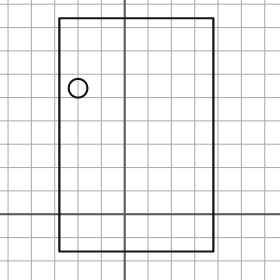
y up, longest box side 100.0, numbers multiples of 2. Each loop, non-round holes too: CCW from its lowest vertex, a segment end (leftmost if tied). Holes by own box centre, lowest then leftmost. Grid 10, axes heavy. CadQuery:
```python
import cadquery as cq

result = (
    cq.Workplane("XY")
    .moveTo(-28.0, -16.0)
    .lineTo(38.0, -16.0)
    .lineTo(38.0, 84.0)
    .lineTo(-28.0, 84.0)
    .close()
    .moveTo(-20.0, 54.0)
    .circle(4.0)
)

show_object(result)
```